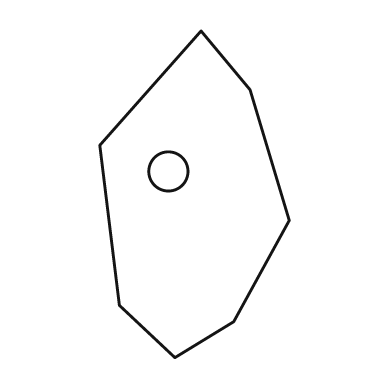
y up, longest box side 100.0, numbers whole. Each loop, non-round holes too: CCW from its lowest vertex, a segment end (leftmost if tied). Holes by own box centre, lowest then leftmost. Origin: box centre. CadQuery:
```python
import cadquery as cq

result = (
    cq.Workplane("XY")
    .moveTo(-6.0, -50.0)
    .lineTo(12.0, -39.0)
    .lineTo(29.0, -8.0)
    .lineTo(17.0, 32.0)
    .lineTo(2.0, 50.0)
    .lineTo(-29.0, 15.0)
    .lineTo(-23.0, -34.0)
    .close()
    .moveTo(-8.0, 7.0)
    .circle(6.0)
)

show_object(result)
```